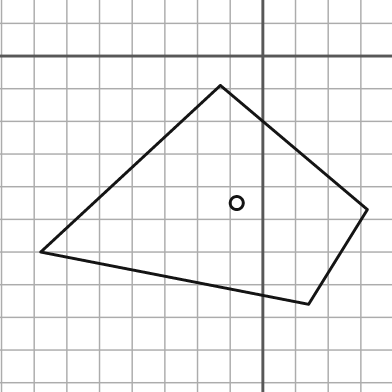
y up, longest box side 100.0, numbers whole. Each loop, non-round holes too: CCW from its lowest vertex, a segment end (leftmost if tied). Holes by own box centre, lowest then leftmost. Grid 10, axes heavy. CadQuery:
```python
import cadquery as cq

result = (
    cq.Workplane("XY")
    .moveTo(14.0, -76.0)
    .lineTo(32.0, -47.0)
    .lineTo(-13.0, -9.0)
    .lineTo(-68.0, -60.0)
    .close()
    .moveTo(-8.0, -45.0)
    .circle(2.0)
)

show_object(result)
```